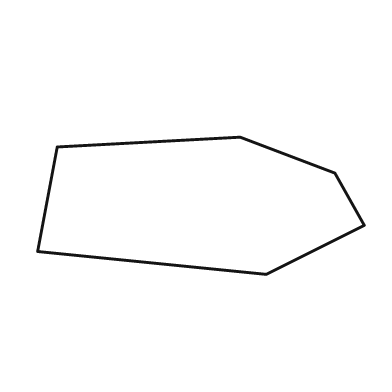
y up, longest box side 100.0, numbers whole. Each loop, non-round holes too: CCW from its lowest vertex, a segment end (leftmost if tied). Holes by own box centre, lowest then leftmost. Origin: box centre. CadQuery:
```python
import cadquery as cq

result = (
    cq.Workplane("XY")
    .moveTo(20.0, -21.0)
    .lineTo(50.0, -6.0)
    .lineTo(41.0, 10.0)
    .lineTo(12.0, 21.0)
    .lineTo(-44.0, 18.0)
    .lineTo(-50.0, -14.0)
    .close()
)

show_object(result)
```